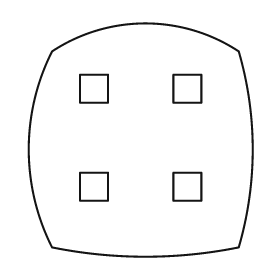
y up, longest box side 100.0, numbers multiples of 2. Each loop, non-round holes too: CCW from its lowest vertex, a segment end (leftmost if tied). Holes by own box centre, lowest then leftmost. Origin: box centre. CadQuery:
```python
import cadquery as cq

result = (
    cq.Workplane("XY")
    .moveTo(-38.0, -46.0)
    .threePointArc((2.0, -50.0), (42.0, -46.0))
    .threePointArc((48.0, -4.0), (42.0, 38.0))
    .threePointArc((2.0, 50.0), (-38.0, 38.0))
    .threePointArc((-48.0, -4.0), (-38.0, -46.0))
    .close()
    .moveTo(-26.0, -26.0)
    .lineTo(-14.0, -26.0)
    .lineTo(-14.0, -14.0)
    .lineTo(-26.0, -14.0)
    .close()
    .moveTo(14.0, -26.0)
    .lineTo(26.0, -26.0)
    .lineTo(26.0, -14.0)
    .lineTo(14.0, -14.0)
    .close()
    .moveTo(-26.0, 16.0)
    .lineTo(-14.0, 16.0)
    .lineTo(-14.0, 28.0)
    .lineTo(-26.0, 28.0)
    .close()
    .moveTo(14.0, 16.0)
    .lineTo(26.0, 16.0)
    .lineTo(26.0, 28.0)
    .lineTo(14.0, 28.0)
    .close()
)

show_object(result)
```